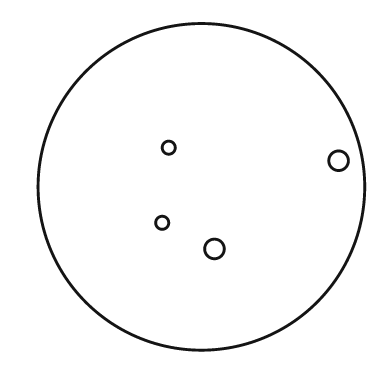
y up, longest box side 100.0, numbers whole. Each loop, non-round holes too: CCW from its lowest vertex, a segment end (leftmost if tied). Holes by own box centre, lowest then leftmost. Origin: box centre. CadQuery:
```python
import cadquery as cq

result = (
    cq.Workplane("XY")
    .moveTo(0.0, 0.0)
    .circle(50.0)
    .moveTo(4.0, -19.0)
    .circle(3.0)
    .moveTo(-12.0, -11.0)
    .circle(2.0)
    .moveTo(42.0, 8.0)
    .circle(3.0)
    .moveTo(-10.0, 12.0)
    .circle(2.0)
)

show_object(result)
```